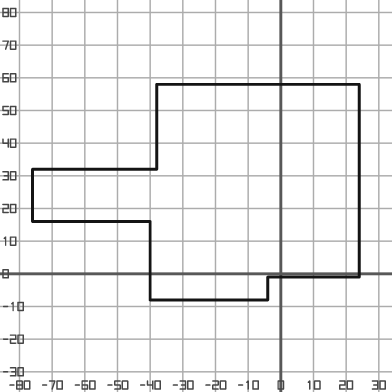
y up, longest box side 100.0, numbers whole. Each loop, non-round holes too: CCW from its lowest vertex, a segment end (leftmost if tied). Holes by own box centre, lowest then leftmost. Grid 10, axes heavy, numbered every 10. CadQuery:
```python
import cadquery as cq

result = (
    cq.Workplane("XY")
    .moveTo(-40.0, -8.0)
    .lineTo(-4.0, -8.0)
    .lineTo(-4.0, -1.0)
    .lineTo(24.0, -1.0)
    .lineTo(24.0, 58.0)
    .lineTo(-38.0, 58.0)
    .lineTo(-38.0, 32.0)
    .lineTo(-76.0, 32.0)
    .lineTo(-76.0, 16.0)
    .lineTo(-40.0, 16.0)
    .close()
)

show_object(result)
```